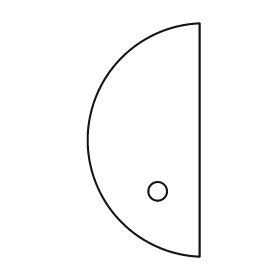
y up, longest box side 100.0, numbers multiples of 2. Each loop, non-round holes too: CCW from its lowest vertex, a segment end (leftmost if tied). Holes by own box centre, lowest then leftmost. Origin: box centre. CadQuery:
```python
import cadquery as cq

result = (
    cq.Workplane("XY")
    .moveTo(24.0, -50.0)
    .lineTo(24.0, 50.0)
    .threePointArc((-24.0, 0.0), (24.0, -50.0))
    .close()
    .moveTo(6.0, -22.0)
    .circle(4.0)
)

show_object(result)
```